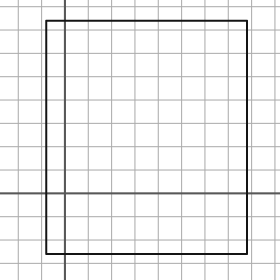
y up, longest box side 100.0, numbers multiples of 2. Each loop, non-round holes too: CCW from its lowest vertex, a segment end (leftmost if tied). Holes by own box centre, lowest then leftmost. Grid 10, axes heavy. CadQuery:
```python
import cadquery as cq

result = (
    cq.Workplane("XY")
    .moveTo(-8.0, -26.0)
    .lineTo(78.0, -26.0)
    .lineTo(78.0, 74.0)
    .lineTo(-8.0, 74.0)
    .close()
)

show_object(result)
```